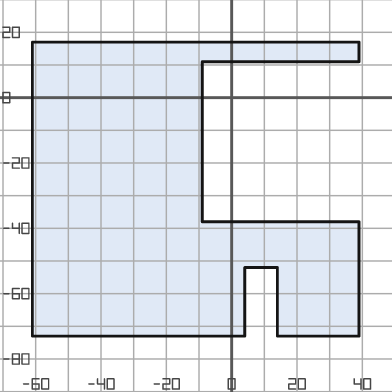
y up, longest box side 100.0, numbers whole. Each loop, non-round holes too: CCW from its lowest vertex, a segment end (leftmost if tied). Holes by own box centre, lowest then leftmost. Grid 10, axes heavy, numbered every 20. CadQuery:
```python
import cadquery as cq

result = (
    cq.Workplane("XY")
    .moveTo(-61.0, -73.0)
    .lineTo(4.0, -73.0)
    .lineTo(4.0, -52.0)
    .lineTo(14.0, -52.0)
    .lineTo(14.0, -73.0)
    .lineTo(39.0, -73.0)
    .lineTo(39.0, -38.0)
    .lineTo(-9.0, -38.0)
    .lineTo(-9.0, 11.0)
    .lineTo(39.0, 11.0)
    .lineTo(39.0, 17.0)
    .lineTo(-61.0, 17.0)
    .close()
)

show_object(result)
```